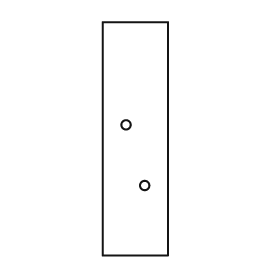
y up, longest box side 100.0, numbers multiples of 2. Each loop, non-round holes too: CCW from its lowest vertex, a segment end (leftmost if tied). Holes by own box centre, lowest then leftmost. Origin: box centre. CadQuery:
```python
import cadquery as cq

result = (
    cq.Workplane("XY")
    .moveTo(-14.0, -50.0)
    .lineTo(14.0, -50.0)
    .lineTo(14.0, 50.0)
    .lineTo(-14.0, 50.0)
    .close()
    .moveTo(4.0, -20.0)
    .circle(2.0)
    .moveTo(-4.0, 6.0)
    .circle(2.0)
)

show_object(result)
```